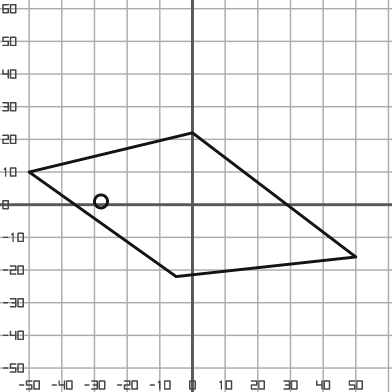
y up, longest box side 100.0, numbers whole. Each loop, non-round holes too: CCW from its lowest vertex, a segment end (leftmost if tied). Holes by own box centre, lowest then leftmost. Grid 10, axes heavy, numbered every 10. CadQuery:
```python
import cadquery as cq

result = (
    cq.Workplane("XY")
    .moveTo(-5.0, -22.0)
    .lineTo(50.0, -16.0)
    .lineTo(0.0, 22.0)
    .lineTo(-50.0, 10.0)
    .close()
    .moveTo(-28.0, 1.0)
    .circle(2.0)
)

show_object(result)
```